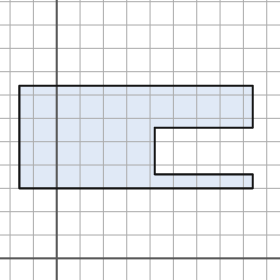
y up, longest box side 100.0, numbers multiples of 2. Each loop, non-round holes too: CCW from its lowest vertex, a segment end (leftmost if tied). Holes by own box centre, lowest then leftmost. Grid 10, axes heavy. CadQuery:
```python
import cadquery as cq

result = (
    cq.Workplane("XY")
    .moveTo(-16.0, 30.0)
    .lineTo(84.0, 30.0)
    .lineTo(84.0, 36.0)
    .lineTo(42.0, 36.0)
    .lineTo(42.0, 56.0)
    .lineTo(84.0, 56.0)
    .lineTo(84.0, 74.0)
    .lineTo(-16.0, 74.0)
    .close()
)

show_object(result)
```